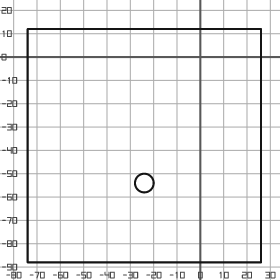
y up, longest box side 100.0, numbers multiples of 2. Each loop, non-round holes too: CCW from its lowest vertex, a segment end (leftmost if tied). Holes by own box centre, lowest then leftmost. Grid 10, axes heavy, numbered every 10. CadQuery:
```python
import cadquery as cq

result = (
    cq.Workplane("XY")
    .moveTo(-74.0, -88.0)
    .lineTo(26.0, -88.0)
    .lineTo(26.0, 12.0)
    .lineTo(-74.0, 12.0)
    .close()
    .moveTo(-24.0, -54.0)
    .circle(4.0)
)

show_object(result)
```